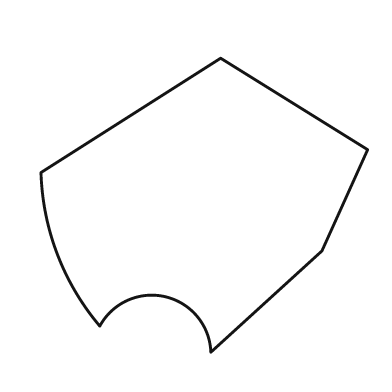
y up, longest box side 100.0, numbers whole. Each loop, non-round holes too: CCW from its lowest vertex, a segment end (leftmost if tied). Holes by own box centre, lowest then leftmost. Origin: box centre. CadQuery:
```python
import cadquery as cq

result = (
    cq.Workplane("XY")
    .moveTo(2.0, -45.0)
    .lineTo(36.0, -14.0)
    .lineTo(50.0, 17.0)
    .lineTo(5.0, 45.0)
    .lineTo(-50.0, 10.0)
    .threePointArc((-45.0, -15.0), (-32.0, -37.0))
    .threePointArc((-12.0, -28.0), (2.0, -45.0))
    .close()
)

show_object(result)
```